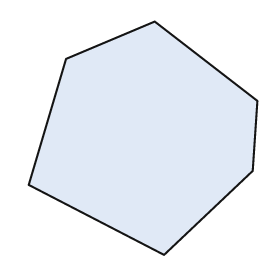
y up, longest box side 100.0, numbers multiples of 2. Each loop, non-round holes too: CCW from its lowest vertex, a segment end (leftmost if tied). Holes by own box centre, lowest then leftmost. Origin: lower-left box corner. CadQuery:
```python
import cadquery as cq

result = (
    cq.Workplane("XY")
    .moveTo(58.0, 0.0)
    .lineTo(96.0, 36.0)
    .lineTo(98.0, 66.0)
    .lineTo(54.0, 100.0)
    .lineTo(16.0, 84.0)
    .lineTo(0.0, 30.0)
    .close()
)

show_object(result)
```